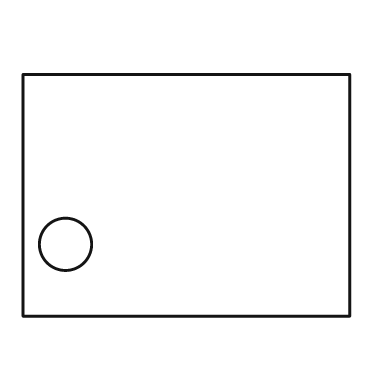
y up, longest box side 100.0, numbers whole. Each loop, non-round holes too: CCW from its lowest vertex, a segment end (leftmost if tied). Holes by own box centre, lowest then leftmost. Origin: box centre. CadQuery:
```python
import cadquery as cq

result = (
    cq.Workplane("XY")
    .moveTo(-50.0, -37.0)
    .lineTo(50.0, -37.0)
    .lineTo(50.0, 37.0)
    .lineTo(-50.0, 37.0)
    .close()
    .moveTo(-37.0, -15.0)
    .circle(8.0)
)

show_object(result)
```